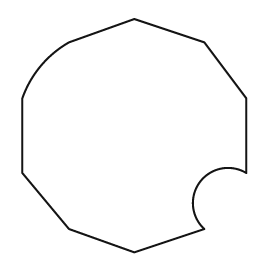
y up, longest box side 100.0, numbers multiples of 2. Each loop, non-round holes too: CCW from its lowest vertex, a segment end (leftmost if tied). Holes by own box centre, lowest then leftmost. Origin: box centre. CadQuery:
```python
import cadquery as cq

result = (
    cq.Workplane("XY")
    .moveTo(0.0, -50.0)
    .lineTo(30.0, -40.0)
    .threePointArc((28.0, -20.0), (48.0, -16.0))
    .lineTo(48.0, 16.0)
    .lineTo(30.0, 40.0)
    .lineTo(0.0, 50.0)
    .lineTo(-28.0, 40.0)
    .threePointArc((-40.0, 30.0), (-48.0, 16.0))
    .lineTo(-48.0, -16.0)
    .lineTo(-28.0, -40.0)
    .close()
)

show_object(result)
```